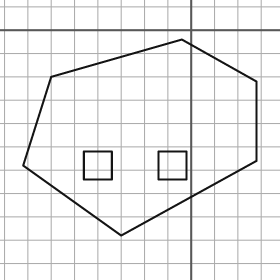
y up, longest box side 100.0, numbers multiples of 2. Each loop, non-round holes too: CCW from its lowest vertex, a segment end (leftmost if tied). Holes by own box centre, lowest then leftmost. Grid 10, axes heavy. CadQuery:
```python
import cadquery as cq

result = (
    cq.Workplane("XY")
    .moveTo(-30.0, -88.0)
    .lineTo(28.0, -56.0)
    .lineTo(28.0, -22.0)
    .lineTo(-4.0, -4.0)
    .lineTo(-60.0, -20.0)
    .lineTo(-72.0, -58.0)
    .close()
    .moveTo(-46.0, -64.0)
    .lineTo(-34.0, -64.0)
    .lineTo(-34.0, -52.0)
    .lineTo(-46.0, -52.0)
    .close()
    .moveTo(-14.0, -64.0)
    .lineTo(-2.0, -64.0)
    .lineTo(-2.0, -52.0)
    .lineTo(-14.0, -52.0)
    .close()
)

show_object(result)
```